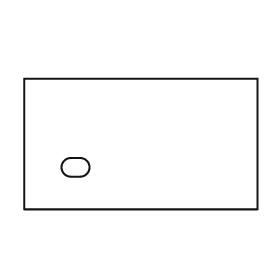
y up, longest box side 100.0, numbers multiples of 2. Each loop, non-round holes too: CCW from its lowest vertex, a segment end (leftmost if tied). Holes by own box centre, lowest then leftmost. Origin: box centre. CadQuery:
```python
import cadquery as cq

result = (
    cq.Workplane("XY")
    .moveTo(-50.0, -28.0)
    .lineTo(50.0, -28.0)
    .lineTo(50.0, 28.0)
    .lineTo(-50.0, 28.0)
    .close()
    .moveTo(-30.0, -14.0)
    .lineTo(-26.0, -14.0)
    .threePointArc((-22.0, -10.0), (-26.0, -6.0))
    .lineTo(-30.0, -6.0)
    .threePointArc((-34.0, -10.0), (-30.0, -14.0))
    .close()
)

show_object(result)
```